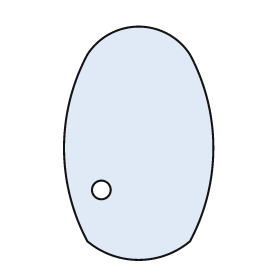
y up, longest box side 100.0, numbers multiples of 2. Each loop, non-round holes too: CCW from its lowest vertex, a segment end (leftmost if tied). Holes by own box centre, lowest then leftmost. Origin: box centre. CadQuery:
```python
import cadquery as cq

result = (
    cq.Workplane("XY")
    .moveTo(-22.0, -42.0)
    .threePointArc((0.0, -50.0), (22.0, -42.0))
    .threePointArc((32.0, -2.0), (22.0, 38.0))
    .threePointArc((0.0, 50.0), (-22.0, 38.0))
    .threePointArc((-32.0, -2.0), (-22.0, -42.0))
    .close()
    .moveTo(-16.0, -20.0)
    .circle(4.0)
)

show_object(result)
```